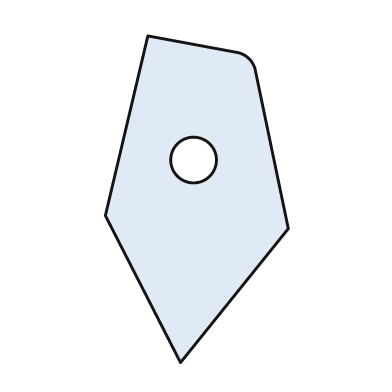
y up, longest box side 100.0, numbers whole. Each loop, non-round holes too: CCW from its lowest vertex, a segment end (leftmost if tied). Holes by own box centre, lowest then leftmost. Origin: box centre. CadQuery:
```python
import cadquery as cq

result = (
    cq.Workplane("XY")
    .moveTo(-5.0, -50.0)
    .lineTo(28.0, -9.0)
    .lineTo(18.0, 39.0)
    .threePointArc((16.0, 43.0), (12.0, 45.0))
    .lineTo(-15.0, 50.0)
    .lineTo(-28.0, -5.0)
    .close()
    .moveTo(-1.0, 12.0)
    .circle(7.0)
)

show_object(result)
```